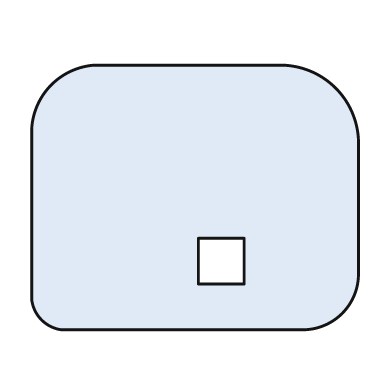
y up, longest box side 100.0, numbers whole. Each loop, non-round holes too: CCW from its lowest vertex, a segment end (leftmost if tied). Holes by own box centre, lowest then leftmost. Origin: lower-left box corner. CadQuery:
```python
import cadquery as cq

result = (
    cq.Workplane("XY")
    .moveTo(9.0, 0.0)
    .lineTo(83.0, 0.0)
    .threePointArc((95.0, 5.0), (100.0, 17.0))
    .lineTo(100.0, 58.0)
    .threePointArc((93.0, 74.0), (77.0, 81.0))
    .lineTo(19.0, 81.0)
    .threePointArc((6.0, 75.0), (0.0, 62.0))
    .lineTo(0.0, 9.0)
    .threePointArc((3.0, 3.0), (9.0, 0.0))
    .close()
    .moveTo(51.0, 14.0)
    .lineTo(65.0, 14.0)
    .lineTo(65.0, 28.0)
    .lineTo(51.0, 28.0)
    .close()
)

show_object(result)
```